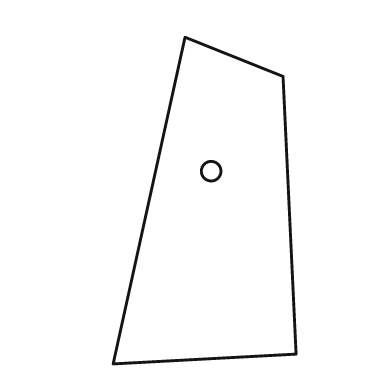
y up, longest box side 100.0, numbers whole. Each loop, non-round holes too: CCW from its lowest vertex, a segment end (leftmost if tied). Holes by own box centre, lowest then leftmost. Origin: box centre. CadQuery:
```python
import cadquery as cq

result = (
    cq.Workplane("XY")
    .moveTo(-28.0, -50.0)
    .lineTo(28.0, -47.0)
    .lineTo(24.0, 38.0)
    .lineTo(-6.0, 50.0)
    .close()
    .moveTo(2.0, 9.0)
    .circle(3.0)
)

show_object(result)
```